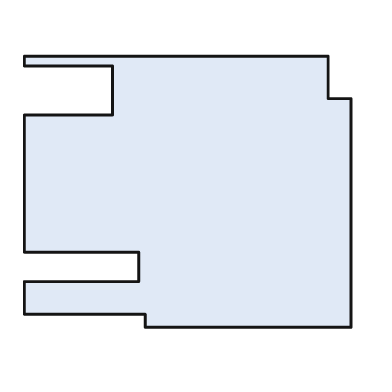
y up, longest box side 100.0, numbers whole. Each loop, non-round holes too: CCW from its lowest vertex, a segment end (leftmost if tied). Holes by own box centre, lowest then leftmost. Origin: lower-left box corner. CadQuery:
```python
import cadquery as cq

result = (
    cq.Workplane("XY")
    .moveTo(37.0, 0.0)
    .lineTo(100.0, 0.0)
    .lineTo(100.0, 70.0)
    .lineTo(93.0, 70.0)
    .lineTo(93.0, 83.0)
    .lineTo(0.0, 83.0)
    .lineTo(0.0, 80.0)
    .lineTo(27.0, 80.0)
    .lineTo(27.0, 65.0)
    .lineTo(0.0, 65.0)
    .lineTo(0.0, 23.0)
    .lineTo(35.0, 23.0)
    .lineTo(35.0, 14.0)
    .lineTo(0.0, 14.0)
    .lineTo(0.0, 4.0)
    .lineTo(37.0, 4.0)
    .close()
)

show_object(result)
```